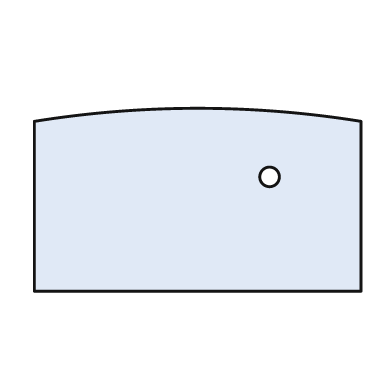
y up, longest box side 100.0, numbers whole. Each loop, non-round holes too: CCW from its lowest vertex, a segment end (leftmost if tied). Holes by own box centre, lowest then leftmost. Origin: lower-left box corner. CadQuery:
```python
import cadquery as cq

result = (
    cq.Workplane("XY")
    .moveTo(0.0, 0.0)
    .lineTo(100.0, 0.0)
    .lineTo(100.0, 52.0)
    .threePointArc((50.0, 56.0), (0.0, 52.0))
    .close()
    .moveTo(72.0, 35.0)
    .circle(3.0)
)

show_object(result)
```